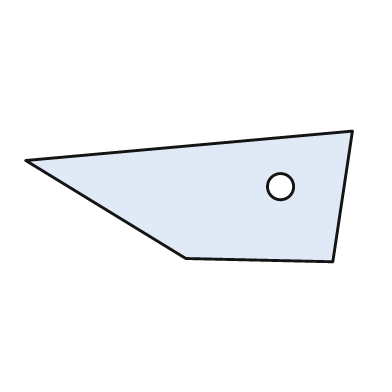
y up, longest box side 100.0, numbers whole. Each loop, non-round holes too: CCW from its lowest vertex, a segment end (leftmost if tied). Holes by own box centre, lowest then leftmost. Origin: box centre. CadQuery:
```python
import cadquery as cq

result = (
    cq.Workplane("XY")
    .moveTo(44.0, -20.0)
    .lineTo(50.0, 20.0)
    .lineTo(-50.0, 11.0)
    .lineTo(-1.0, -19.0)
    .close()
    .moveTo(28.0, 3.0)
    .circle(4.0)
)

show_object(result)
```